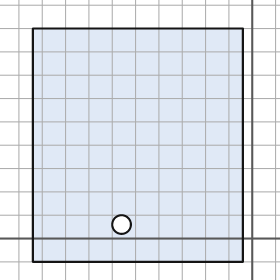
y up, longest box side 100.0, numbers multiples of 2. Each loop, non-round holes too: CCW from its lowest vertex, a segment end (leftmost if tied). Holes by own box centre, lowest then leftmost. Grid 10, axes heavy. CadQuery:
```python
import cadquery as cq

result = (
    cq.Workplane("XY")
    .moveTo(-94.0, -10.0)
    .lineTo(-4.0, -10.0)
    .lineTo(-4.0, 90.0)
    .lineTo(-94.0, 90.0)
    .close()
    .moveTo(-56.0, 6.0)
    .circle(4.0)
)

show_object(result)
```